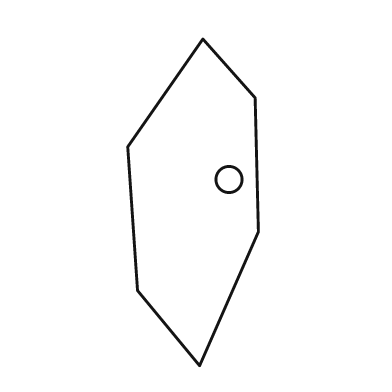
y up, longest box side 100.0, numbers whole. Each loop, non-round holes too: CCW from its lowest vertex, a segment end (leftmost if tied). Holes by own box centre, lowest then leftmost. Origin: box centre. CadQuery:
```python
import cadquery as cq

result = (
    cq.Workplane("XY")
    .moveTo(2.0, -50.0)
    .lineTo(20.0, -9.0)
    .lineTo(19.0, 32.0)
    .lineTo(3.0, 50.0)
    .lineTo(-20.0, 17.0)
    .lineTo(-17.0, -27.0)
    .close()
    .moveTo(11.0, 7.0)
    .circle(4.0)
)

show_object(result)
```